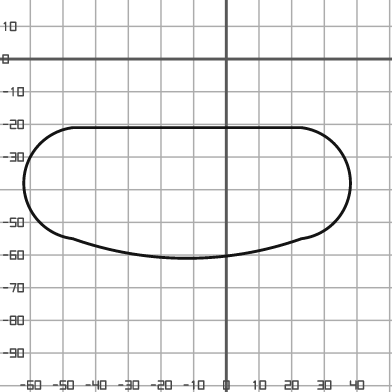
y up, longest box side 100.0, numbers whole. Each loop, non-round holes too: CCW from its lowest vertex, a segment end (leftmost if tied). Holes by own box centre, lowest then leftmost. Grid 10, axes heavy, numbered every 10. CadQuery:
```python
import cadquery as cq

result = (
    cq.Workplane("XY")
    .moveTo(-47.0, -55.0)
    .threePointArc((-12.0, -61.0), (23.0, -55.0))
    .threePointArc((38.0, -38.0), (23.0, -21.0))
    .lineTo(-47.0, -21.0)
    .threePointArc((-62.0, -38.0), (-47.0, -55.0))
    .close()
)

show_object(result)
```